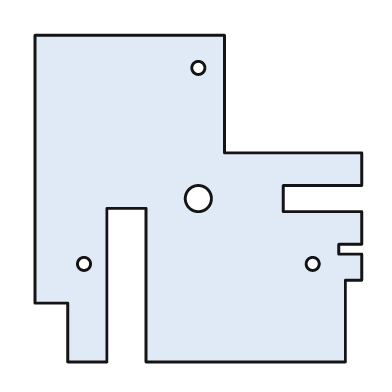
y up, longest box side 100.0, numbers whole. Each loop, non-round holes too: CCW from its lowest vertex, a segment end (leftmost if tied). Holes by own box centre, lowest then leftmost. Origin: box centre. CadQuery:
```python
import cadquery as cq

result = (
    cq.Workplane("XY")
    .moveTo(-40.0, -50.0)
    .lineTo(-28.0, -50.0)
    .lineTo(-28.0, -3.0)
    .lineTo(-16.0, -3.0)
    .lineTo(-16.0, -50.0)
    .lineTo(45.0, -50.0)
    .lineTo(45.0, -25.0)
    .lineTo(50.0, -25.0)
    .lineTo(50.0, -17.0)
    .lineTo(43.0, -17.0)
    .lineTo(43.0, -14.0)
    .lineTo(50.0, -14.0)
    .lineTo(50.0, -4.0)
    .lineTo(26.0, -4.0)
    .lineTo(26.0, 4.0)
    .lineTo(50.0, 4.0)
    .lineTo(50.0, 14.0)
    .lineTo(8.0, 14.0)
    .lineTo(8.0, 50.0)
    .lineTo(-50.0, 50.0)
    .lineTo(-50.0, -32.0)
    .lineTo(-40.0, -32.0)
    .close()
    .moveTo(-35.0, -20.0)
    .circle(2.0)
    .moveTo(35.0, -20.0)
    .circle(2.0)
    .moveTo(0.0, 0.0)
    .circle(4.0)
    .moveTo(0.0, 40.0)
    .circle(2.0)
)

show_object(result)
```